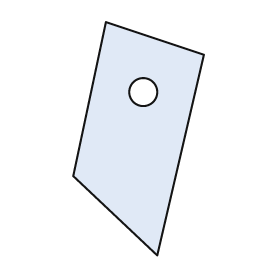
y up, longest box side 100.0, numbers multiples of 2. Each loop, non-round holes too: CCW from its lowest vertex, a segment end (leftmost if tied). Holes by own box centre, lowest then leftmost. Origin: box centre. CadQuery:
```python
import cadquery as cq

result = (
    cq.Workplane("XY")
    .moveTo(8.0, -50.0)
    .lineTo(28.0, 36.0)
    .lineTo(-14.0, 50.0)
    .lineTo(-28.0, -16.0)
    .close()
    .moveTo(2.0, 20.0)
    .circle(6.0)
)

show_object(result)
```